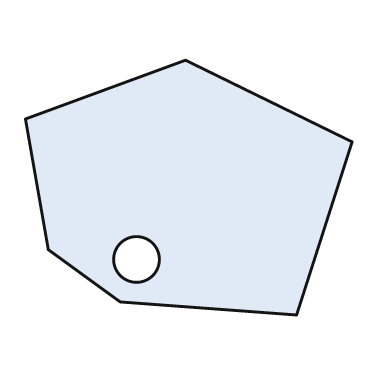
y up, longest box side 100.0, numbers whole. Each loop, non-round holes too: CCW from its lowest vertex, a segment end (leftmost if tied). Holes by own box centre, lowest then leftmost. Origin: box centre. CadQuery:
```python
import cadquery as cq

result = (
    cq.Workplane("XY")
    .moveTo(33.0, -39.0)
    .lineTo(50.0, 14.0)
    .lineTo(-1.0, 39.0)
    .lineTo(-50.0, 21.0)
    .lineTo(-43.0, -19.0)
    .lineTo(-21.0, -35.0)
    .close()
    .moveTo(-16.0, -22.0)
    .circle(7.0)
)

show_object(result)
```